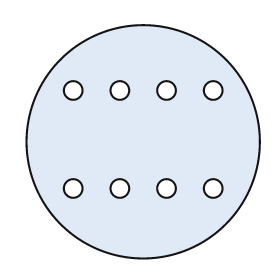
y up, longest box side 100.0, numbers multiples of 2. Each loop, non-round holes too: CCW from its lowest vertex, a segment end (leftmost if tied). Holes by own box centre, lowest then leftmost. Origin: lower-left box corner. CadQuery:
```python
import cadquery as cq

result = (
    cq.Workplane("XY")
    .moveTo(50.0, 50.0)
    .circle(50.0)
    .moveTo(20.0, 30.0)
    .circle(4.0)
    .moveTo(40.0, 30.0)
    .circle(4.0)
    .moveTo(60.0, 30.0)
    .circle(4.0)
    .moveTo(80.0, 30.0)
    .circle(4.0)
    .moveTo(20.0, 72.0)
    .circle(4.0)
    .moveTo(40.0, 72.0)
    .circle(4.0)
    .moveTo(60.0, 72.0)
    .circle(4.0)
    .moveTo(80.0, 72.0)
    .circle(4.0)
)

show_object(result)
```